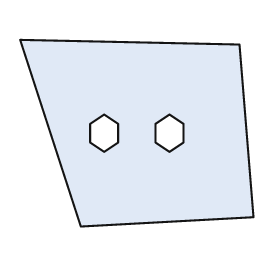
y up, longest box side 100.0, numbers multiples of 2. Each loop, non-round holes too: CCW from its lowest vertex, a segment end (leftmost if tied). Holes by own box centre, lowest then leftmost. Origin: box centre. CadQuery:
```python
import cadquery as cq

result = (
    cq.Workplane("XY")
    .moveTo(-24.0, -40.0)
    .lineTo(50.0, -36.0)
    .lineTo(44.0, 38.0)
    .lineTo(-50.0, 40.0)
    .close()
    .moveTo(-14.0, -8.0)
    .lineTo(-8.0, -4.0)
    .lineTo(-8.0, 4.0)
    .lineTo(-14.0, 8.0)
    .lineTo(-20.0, 4.0)
    .lineTo(-20.0, -4.0)
    .close()
    .moveTo(14.0, -8.0)
    .lineTo(20.0, -4.0)
    .lineTo(20.0, 4.0)
    .lineTo(14.0, 8.0)
    .lineTo(8.0, 4.0)
    .lineTo(8.0, -4.0)
    .close()
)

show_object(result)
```